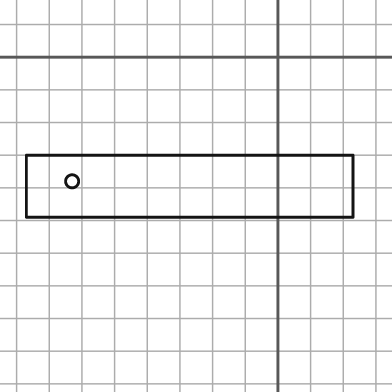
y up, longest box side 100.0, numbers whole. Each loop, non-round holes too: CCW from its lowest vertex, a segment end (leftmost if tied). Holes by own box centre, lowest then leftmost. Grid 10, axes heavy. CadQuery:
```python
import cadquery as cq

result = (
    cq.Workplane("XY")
    .moveTo(-77.0, -49.0)
    .lineTo(23.0, -49.0)
    .lineTo(23.0, -30.0)
    .lineTo(-77.0, -30.0)
    .close()
    .moveTo(-63.0, -38.0)
    .circle(2.0)
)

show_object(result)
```